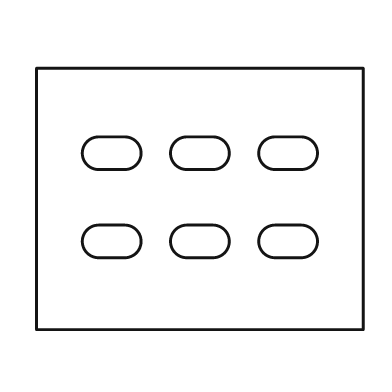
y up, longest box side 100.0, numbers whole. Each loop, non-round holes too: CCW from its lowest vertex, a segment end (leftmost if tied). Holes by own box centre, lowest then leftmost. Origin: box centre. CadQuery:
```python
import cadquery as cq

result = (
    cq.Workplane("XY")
    .moveTo(-50.0, -40.0)
    .lineTo(50.0, -40.0)
    .lineTo(50.0, 40.0)
    .lineTo(-50.0, 40.0)
    .close()
    .moveTo(-31.0, -18.0)
    .lineTo(-23.0, -18.0)
    .threePointArc((-18.0, -13.0), (-23.0, -8.0))
    .lineTo(-31.0, -8.0)
    .threePointArc((-36.0, -13.0), (-31.0, -18.0))
    .close()
    .moveTo(-4.0, -18.0)
    .lineTo(4.0, -18.0)
    .threePointArc((9.0, -13.0), (4.0, -8.0))
    .lineTo(-4.0, -8.0)
    .threePointArc((-9.0, -13.0), (-4.0, -18.0))
    .close()
    .moveTo(23.0, -18.0)
    .lineTo(31.0, -18.0)
    .threePointArc((36.0, -13.0), (31.0, -8.0))
    .lineTo(23.0, -8.0)
    .threePointArc((18.0, -13.0), (23.0, -18.0))
    .close()
    .moveTo(-31.0, 9.0)
    .lineTo(-23.0, 9.0)
    .threePointArc((-18.0, 14.0), (-23.0, 19.0))
    .lineTo(-31.0, 19.0)
    .threePointArc((-36.0, 14.0), (-31.0, 9.0))
    .close()
    .moveTo(-4.0, 9.0)
    .lineTo(4.0, 9.0)
    .threePointArc((9.0, 14.0), (4.0, 19.0))
    .lineTo(-4.0, 19.0)
    .threePointArc((-9.0, 14.0), (-4.0, 9.0))
    .close()
    .moveTo(23.0, 9.0)
    .lineTo(31.0, 9.0)
    .threePointArc((36.0, 14.0), (31.0, 19.0))
    .lineTo(23.0, 19.0)
    .threePointArc((18.0, 14.0), (23.0, 9.0))
    .close()
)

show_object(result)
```